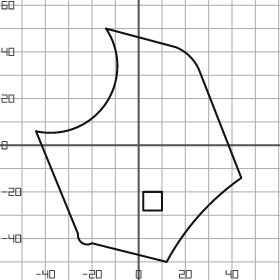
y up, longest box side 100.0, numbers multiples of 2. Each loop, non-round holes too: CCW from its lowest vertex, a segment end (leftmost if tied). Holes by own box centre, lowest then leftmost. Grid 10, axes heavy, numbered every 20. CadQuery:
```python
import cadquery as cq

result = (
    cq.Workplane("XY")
    .moveTo(12.0, -50.0)
    .threePointArc((26.0, -30.0), (44.0, -14.0))
    .lineTo(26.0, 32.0)
    .threePointArc((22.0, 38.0), (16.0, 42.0))
    .lineTo(-14.0, 50.0)
    .threePointArc((-14.0, 18.0), (-44.0, 6.0))
    .lineTo(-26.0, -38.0)
    .threePointArc((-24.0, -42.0), (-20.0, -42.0))
    .close()
    .moveTo(2.0, -28.0)
    .lineTo(10.0, -28.0)
    .lineTo(10.0, -20.0)
    .lineTo(2.0, -20.0)
    .close()
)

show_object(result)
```